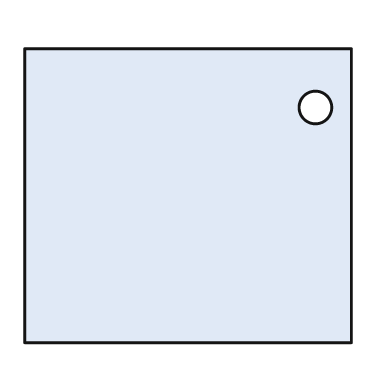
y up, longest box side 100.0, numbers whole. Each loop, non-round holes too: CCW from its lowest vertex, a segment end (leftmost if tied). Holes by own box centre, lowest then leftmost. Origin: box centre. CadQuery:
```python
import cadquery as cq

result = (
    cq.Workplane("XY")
    .moveTo(-50.0, -45.0)
    .lineTo(50.0, -45.0)
    .lineTo(50.0, 45.0)
    .lineTo(-50.0, 45.0)
    .close()
    .moveTo(39.0, 27.0)
    .circle(5.0)
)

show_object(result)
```